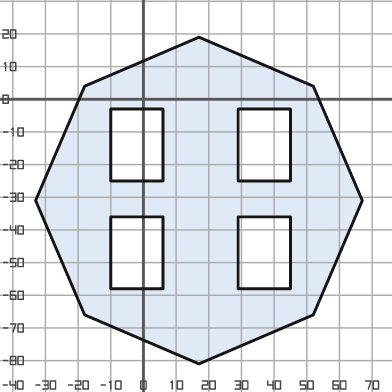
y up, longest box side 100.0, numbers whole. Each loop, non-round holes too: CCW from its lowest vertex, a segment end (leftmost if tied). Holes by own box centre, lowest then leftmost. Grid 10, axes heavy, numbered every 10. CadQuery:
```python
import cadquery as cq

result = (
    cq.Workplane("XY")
    .moveTo(17.0, -81.0)
    .lineTo(52.0, -66.0)
    .lineTo(67.0, -31.0)
    .lineTo(52.0, 4.0)
    .lineTo(17.0, 19.0)
    .lineTo(-18.0, 4.0)
    .lineTo(-33.0, -31.0)
    .lineTo(-18.0, -66.0)
    .close()
    .moveTo(-10.0, -58.0)
    .lineTo(6.0, -58.0)
    .lineTo(6.0, -36.0)
    .lineTo(-10.0, -36.0)
    .close()
    .moveTo(29.0, -58.0)
    .lineTo(45.0, -58.0)
    .lineTo(45.0, -36.0)
    .lineTo(29.0, -36.0)
    .close()
    .moveTo(-10.0, -25.0)
    .lineTo(6.0, -25.0)
    .lineTo(6.0, -3.0)
    .lineTo(-10.0, -3.0)
    .close()
    .moveTo(29.0, -25.0)
    .lineTo(45.0, -25.0)
    .lineTo(45.0, -3.0)
    .lineTo(29.0, -3.0)
    .close()
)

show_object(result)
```